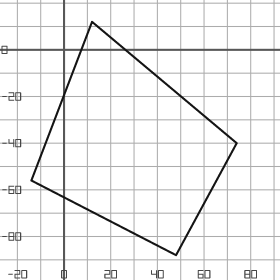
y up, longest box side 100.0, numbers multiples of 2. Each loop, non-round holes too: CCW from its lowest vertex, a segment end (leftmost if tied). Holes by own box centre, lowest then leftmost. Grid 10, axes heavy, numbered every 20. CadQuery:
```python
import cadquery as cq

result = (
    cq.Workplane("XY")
    .moveTo(48.0, -88.0)
    .lineTo(74.0, -40.0)
    .lineTo(12.0, 12.0)
    .lineTo(-14.0, -56.0)
    .close()
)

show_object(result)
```